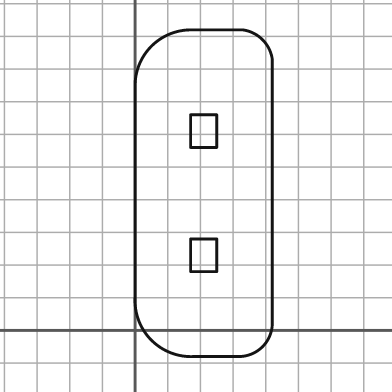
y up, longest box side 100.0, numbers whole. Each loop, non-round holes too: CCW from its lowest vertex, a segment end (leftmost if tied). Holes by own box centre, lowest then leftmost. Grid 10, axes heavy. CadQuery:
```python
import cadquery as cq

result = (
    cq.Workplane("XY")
    .moveTo(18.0, -8.0)
    .lineTo(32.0, -8.0)
    .threePointArc((39.0, -5.0), (42.0, 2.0))
    .lineTo(42.0, 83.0)
    .threePointArc((39.0, 89.0), (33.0, 92.0))
    .lineTo(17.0, 92.0)
    .threePointArc((5.0, 87.0), (0.0, 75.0))
    .lineTo(0.0, 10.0)
    .threePointArc((5.0, -3.0), (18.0, -8.0))
    .close()
    .moveTo(17.0, 18.0)
    .lineTo(25.0, 18.0)
    .lineTo(25.0, 28.0)
    .lineTo(17.0, 28.0)
    .close()
    .moveTo(17.0, 56.0)
    .lineTo(25.0, 56.0)
    .lineTo(25.0, 66.0)
    .lineTo(17.0, 66.0)
    .close()
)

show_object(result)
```